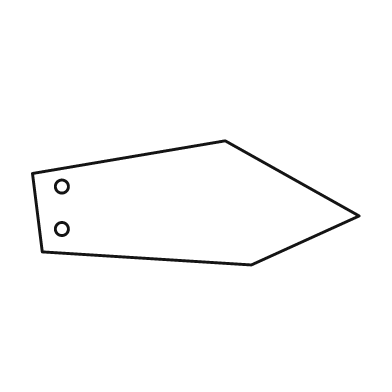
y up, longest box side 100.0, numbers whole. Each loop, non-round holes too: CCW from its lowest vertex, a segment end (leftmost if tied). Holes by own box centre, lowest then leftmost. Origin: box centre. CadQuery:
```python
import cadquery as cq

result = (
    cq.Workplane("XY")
    .moveTo(17.0, -19.0)
    .lineTo(50.0, -4.0)
    .lineTo(9.0, 19.0)
    .lineTo(-50.0, 9.0)
    .lineTo(-47.0, -15.0)
    .close()
    .moveTo(-41.0, -8.0)
    .circle(2.0)
    .moveTo(-41.0, 5.0)
    .circle(2.0)
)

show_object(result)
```